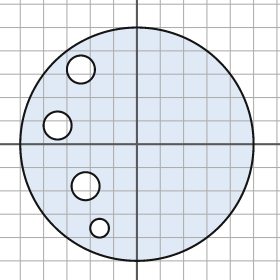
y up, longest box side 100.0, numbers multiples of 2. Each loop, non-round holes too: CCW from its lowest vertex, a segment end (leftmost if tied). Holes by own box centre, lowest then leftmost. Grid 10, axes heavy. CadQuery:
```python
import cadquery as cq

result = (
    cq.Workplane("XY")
    .moveTo(0.0, 0.0)
    .circle(50.0)
    .moveTo(-16.0, -36.0)
    .circle(4.0)
    .moveTo(-22.0, -18.0)
    .circle(6.0)
    .moveTo(-34.0, 8.0)
    .circle(6.0)
    .moveTo(-24.0, 32.0)
    .circle(6.0)
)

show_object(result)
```